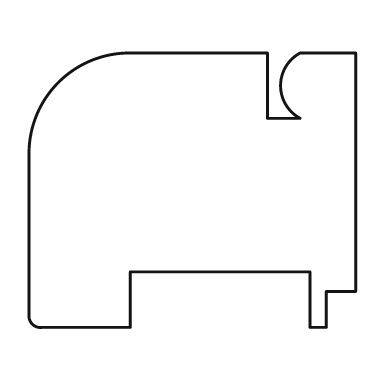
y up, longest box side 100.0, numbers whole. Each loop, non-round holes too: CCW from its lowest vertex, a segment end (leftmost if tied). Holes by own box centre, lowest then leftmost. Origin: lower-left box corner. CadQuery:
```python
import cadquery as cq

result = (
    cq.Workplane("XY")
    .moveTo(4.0, 0.0)
    .lineTo(31.0, 0.0)
    .lineTo(31.0, 17.0)
    .lineTo(86.0, 17.0)
    .lineTo(86.0, 0.0)
    .lineTo(91.0, 0.0)
    .lineTo(91.0, 11.0)
    .lineTo(100.0, 11.0)
    .lineTo(100.0, 84.0)
    .lineTo(83.0, 84.0)
    .threePointArc((77.0, 74.0), (83.0, 64.0))
    .lineTo(73.0, 64.0)
    .lineTo(73.0, 84.0)
    .lineTo(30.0, 84.0)
    .threePointArc((9.0, 75.0), (0.0, 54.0))
    .lineTo(0.0, 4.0)
    .threePointArc((1.0, 1.0), (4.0, 0.0))
    .close()
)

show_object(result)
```